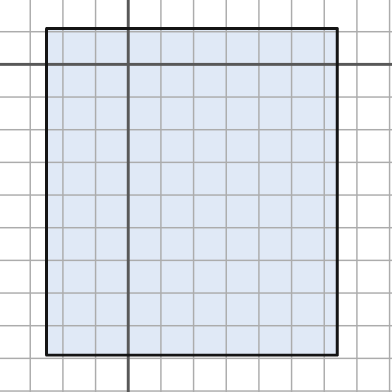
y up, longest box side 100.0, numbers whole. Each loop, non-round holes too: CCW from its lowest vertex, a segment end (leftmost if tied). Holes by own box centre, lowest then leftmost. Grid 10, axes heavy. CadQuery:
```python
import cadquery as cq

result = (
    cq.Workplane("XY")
    .moveTo(-25.0, -89.0)
    .lineTo(64.0, -89.0)
    .lineTo(64.0, 11.0)
    .lineTo(-25.0, 11.0)
    .close()
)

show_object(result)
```